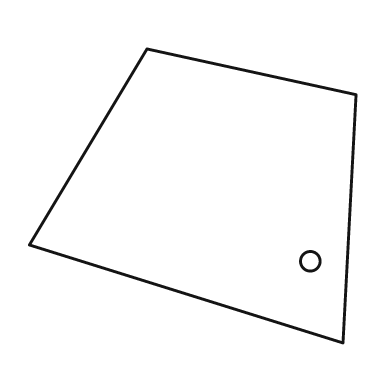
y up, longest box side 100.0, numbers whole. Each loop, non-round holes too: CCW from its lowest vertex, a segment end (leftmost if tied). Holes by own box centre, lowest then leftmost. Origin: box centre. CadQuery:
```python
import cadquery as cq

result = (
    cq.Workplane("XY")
    .moveTo(46.0, -45.0)
    .lineTo(50.0, 31.0)
    .lineTo(-14.0, 45.0)
    .lineTo(-50.0, -15.0)
    .close()
    .moveTo(36.0, -20.0)
    .circle(3.0)
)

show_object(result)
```